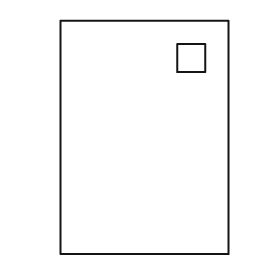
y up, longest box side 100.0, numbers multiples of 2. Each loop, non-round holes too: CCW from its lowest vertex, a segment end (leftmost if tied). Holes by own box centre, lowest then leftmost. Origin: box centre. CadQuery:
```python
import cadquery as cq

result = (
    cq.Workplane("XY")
    .moveTo(-36.0, -50.0)
    .lineTo(36.0, -50.0)
    .lineTo(36.0, 50.0)
    .lineTo(-36.0, 50.0)
    .close()
    .moveTo(14.0, 28.0)
    .lineTo(26.0, 28.0)
    .lineTo(26.0, 40.0)
    .lineTo(14.0, 40.0)
    .close()
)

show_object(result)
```